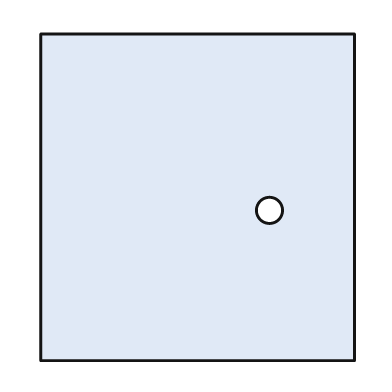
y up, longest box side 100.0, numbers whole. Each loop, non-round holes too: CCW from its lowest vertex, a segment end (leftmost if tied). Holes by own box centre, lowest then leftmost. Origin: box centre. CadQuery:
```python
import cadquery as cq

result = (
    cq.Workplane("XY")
    .moveTo(-48.0, -50.0)
    .lineTo(48.0, -50.0)
    .lineTo(48.0, 50.0)
    .lineTo(-48.0, 50.0)
    .close()
    .moveTo(22.0, -4.0)
    .circle(4.0)
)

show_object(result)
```